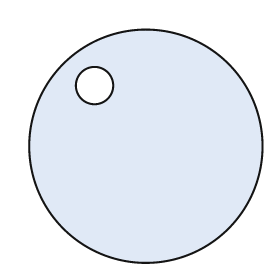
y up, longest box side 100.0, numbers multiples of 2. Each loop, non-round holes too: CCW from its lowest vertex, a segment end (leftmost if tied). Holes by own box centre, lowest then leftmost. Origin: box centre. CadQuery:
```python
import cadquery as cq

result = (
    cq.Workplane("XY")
    .moveTo(0.0, 0.0)
    .circle(50.0)
    .moveTo(-22.0, 26.0)
    .circle(8.0)
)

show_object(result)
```